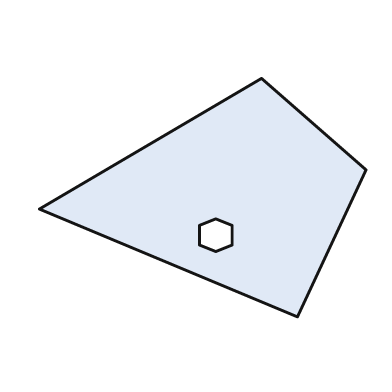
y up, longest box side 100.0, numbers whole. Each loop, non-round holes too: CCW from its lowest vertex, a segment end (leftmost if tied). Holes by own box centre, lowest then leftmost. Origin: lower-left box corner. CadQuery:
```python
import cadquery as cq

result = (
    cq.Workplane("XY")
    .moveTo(79.0, 0.0)
    .lineTo(100.0, 45.0)
    .lineTo(68.0, 73.0)
    .lineTo(0.0, 33.0)
    .close()
    .moveTo(54.0, 20.0)
    .lineTo(59.0, 22.0)
    .lineTo(59.0, 28.0)
    .lineTo(54.0, 30.0)
    .lineTo(49.0, 28.0)
    .lineTo(49.0, 22.0)
    .close()
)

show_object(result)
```